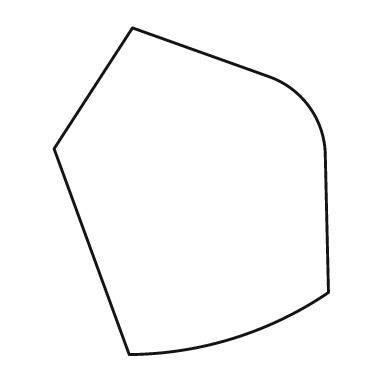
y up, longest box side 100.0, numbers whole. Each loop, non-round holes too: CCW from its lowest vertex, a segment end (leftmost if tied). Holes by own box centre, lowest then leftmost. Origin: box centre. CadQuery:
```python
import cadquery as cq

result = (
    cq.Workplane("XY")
    .moveTo(-19.0, -50.0)
    .threePointArc((13.0, -45.0), (42.0, -31.0))
    .lineTo(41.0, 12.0)
    .threePointArc((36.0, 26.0), (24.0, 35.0))
    .lineTo(-18.0, 50.0)
    .lineTo(-42.0, 13.0)
    .close()
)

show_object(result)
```